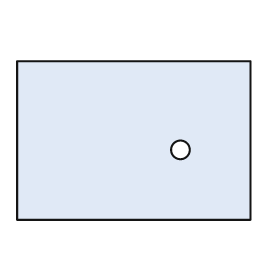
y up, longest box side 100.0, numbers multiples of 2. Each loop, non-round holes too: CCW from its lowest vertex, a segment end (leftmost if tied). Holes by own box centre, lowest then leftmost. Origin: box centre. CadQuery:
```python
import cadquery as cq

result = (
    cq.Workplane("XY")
    .moveTo(-50.0, -34.0)
    .lineTo(50.0, -34.0)
    .lineTo(50.0, 34.0)
    .lineTo(-50.0, 34.0)
    .close()
    .moveTo(20.0, -4.0)
    .circle(4.0)
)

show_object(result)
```